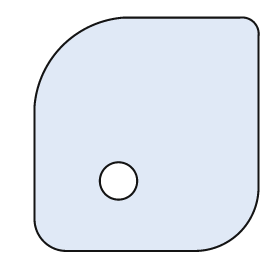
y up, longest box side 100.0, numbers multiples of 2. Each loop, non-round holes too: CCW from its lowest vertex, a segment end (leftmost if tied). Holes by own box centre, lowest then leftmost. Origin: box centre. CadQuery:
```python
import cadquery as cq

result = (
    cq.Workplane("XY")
    .moveTo(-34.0, -50.0)
    .lineTo(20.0, -50.0)
    .threePointArc((40.0, -42.0), (48.0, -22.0))
    .lineTo(48.0, 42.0)
    .threePointArc((46.0, 48.0), (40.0, 50.0))
    .lineTo(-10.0, 50.0)
    .threePointArc((-36.0, 38.0), (-48.0, 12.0))
    .lineTo(-48.0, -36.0)
    .threePointArc((-44.0, -46.0), (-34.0, -50.0))
    .close()
    .moveTo(-12.0, -20.0)
    .circle(8.0)
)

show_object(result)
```